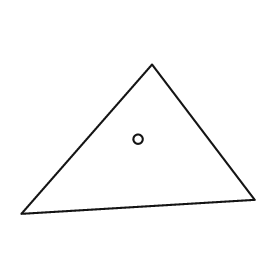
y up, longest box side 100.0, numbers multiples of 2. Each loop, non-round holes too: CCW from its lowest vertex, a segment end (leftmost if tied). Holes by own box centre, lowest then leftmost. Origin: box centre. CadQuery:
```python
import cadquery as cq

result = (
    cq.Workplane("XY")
    .moveTo(-50.0, -32.0)
    .lineTo(50.0, -26.0)
    .lineTo(6.0, 32.0)
    .close()
    .moveTo(0.0, 0.0)
    .circle(2.0)
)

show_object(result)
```